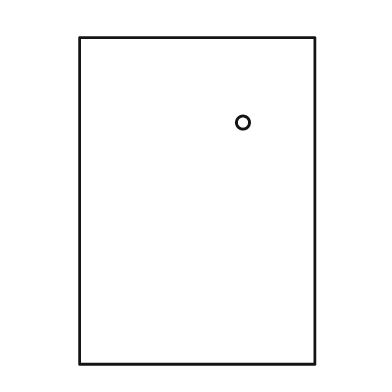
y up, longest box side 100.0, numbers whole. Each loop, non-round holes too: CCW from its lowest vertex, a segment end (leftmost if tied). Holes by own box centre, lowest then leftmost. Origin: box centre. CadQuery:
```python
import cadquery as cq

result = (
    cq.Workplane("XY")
    .moveTo(-36.0, -50.0)
    .lineTo(36.0, -50.0)
    .lineTo(36.0, 50.0)
    .lineTo(-36.0, 50.0)
    .close()
    .moveTo(14.0, 24.0)
    .circle(2.0)
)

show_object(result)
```